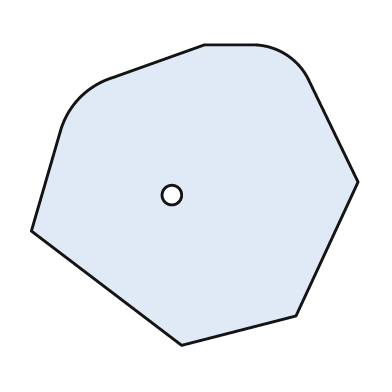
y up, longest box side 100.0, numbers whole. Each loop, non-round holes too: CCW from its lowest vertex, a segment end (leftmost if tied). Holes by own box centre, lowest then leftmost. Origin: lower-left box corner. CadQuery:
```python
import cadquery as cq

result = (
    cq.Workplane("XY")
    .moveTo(46.0, 0.0)
    .lineTo(81.0, 9.0)
    .lineTo(100.0, 50.0)
    .lineTo(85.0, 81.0)
    .threePointArc((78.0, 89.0), (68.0, 92.0))
    .lineTo(53.0, 92.0)
    .lineTo(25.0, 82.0)
    .threePointArc((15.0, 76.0), (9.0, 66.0))
    .lineTo(0.0, 35.0)
    .close()
    .moveTo(43.0, 46.0)
    .circle(3.0)
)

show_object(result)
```